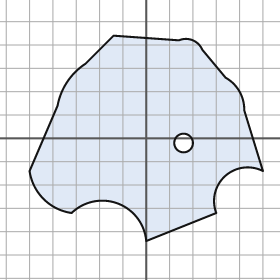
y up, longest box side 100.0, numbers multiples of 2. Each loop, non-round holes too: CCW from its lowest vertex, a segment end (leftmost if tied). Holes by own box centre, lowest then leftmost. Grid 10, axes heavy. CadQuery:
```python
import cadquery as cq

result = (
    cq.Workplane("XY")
    .moveTo(0.0, -44.0)
    .lineTo(30.0, -32.0)
    .threePointArc((34.0, -16.0), (50.0, -14.0))
    .lineTo(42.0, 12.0)
    .threePointArc((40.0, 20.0), (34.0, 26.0))
    .lineTo(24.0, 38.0)
    .threePointArc((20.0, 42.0), (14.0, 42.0))
    .lineTo(-14.0, 44.0)
    .lineTo(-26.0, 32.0)
    .threePointArc((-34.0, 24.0), (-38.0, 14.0))
    .lineTo(-50.0, -14.0)
    .threePointArc((-44.0, -26.0), (-32.0, -32.0))
    .threePointArc((-12.0, -28.0), (0.0, -44.0))
    .close()
    .moveTo(16.0, -2.0)
    .circle(4.0)
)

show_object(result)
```